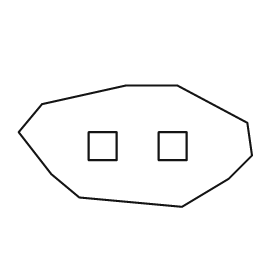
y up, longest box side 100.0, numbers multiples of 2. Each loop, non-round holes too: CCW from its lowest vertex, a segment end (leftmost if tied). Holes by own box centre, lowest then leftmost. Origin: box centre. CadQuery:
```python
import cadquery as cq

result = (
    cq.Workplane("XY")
    .moveTo(20.0, -26.0)
    .lineTo(40.0, -14.0)
    .lineTo(50.0, -4.0)
    .lineTo(48.0, 10.0)
    .lineTo(18.0, 26.0)
    .lineTo(-4.0, 26.0)
    .lineTo(-40.0, 18.0)
    .lineTo(-50.0, 6.0)
    .lineTo(-36.0, -12.0)
    .lineTo(-24.0, -22.0)
    .close()
    .moveTo(-20.0, -6.0)
    .lineTo(-8.0, -6.0)
    .lineTo(-8.0, 6.0)
    .lineTo(-20.0, 6.0)
    .close()
    .moveTo(10.0, -6.0)
    .lineTo(22.0, -6.0)
    .lineTo(22.0, 6.0)
    .lineTo(10.0, 6.0)
    .close()
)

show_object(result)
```